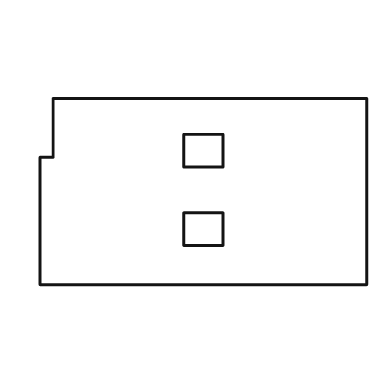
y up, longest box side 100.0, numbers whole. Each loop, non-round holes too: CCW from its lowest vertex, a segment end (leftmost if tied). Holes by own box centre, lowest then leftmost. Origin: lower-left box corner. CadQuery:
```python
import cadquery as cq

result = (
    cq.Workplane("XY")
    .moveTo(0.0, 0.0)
    .lineTo(100.0, 0.0)
    .lineTo(100.0, 57.0)
    .lineTo(4.0, 57.0)
    .lineTo(4.0, 39.0)
    .lineTo(0.0, 39.0)
    .close()
    .moveTo(44.0, 12.0)
    .lineTo(56.0, 12.0)
    .lineTo(56.0, 22.0)
    .lineTo(44.0, 22.0)
    .close()
    .moveTo(44.0, 36.0)
    .lineTo(56.0, 36.0)
    .lineTo(56.0, 46.0)
    .lineTo(44.0, 46.0)
    .close()
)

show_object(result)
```